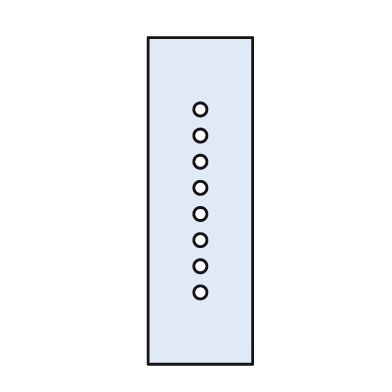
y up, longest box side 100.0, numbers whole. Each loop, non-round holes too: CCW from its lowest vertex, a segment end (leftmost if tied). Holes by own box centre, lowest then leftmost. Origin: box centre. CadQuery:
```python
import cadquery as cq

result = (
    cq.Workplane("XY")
    .moveTo(-16.0, -50.0)
    .lineTo(16.0, -50.0)
    .lineTo(16.0, 50.0)
    .lineTo(-16.0, 50.0)
    .close()
    .moveTo(0.0, -28.0)
    .circle(2.0)
    .moveTo(0.0, -20.0)
    .circle(2.0)
    .moveTo(0.0, -12.0)
    .circle(2.0)
    .moveTo(0.0, -4.0)
    .circle(2.0)
    .moveTo(0.0, 4.0)
    .circle(2.0)
    .moveTo(0.0, 12.0)
    .circle(2.0)
    .moveTo(0.0, 20.0)
    .circle(2.0)
    .moveTo(0.0, 28.0)
    .circle(2.0)
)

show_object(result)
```